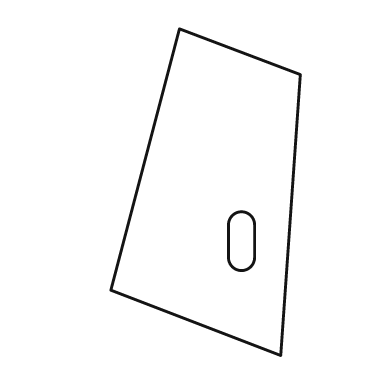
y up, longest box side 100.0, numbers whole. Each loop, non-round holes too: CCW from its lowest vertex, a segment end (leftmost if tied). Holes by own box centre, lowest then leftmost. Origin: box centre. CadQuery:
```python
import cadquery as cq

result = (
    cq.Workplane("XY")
    .moveTo(23.0, -50.0)
    .lineTo(29.0, 36.0)
    .lineTo(-8.0, 50.0)
    .lineTo(-29.0, -30.0)
    .close()
    .moveTo(7.0, -20.0)
    .threePointArc((11.0, -24.0), (15.0, -20.0))
    .lineTo(15.0, -10.0)
    .threePointArc((11.0, -6.0), (7.0, -10.0))
    .close()
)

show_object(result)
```